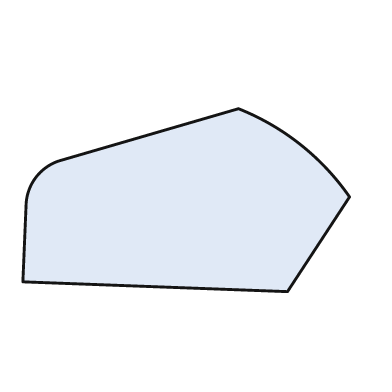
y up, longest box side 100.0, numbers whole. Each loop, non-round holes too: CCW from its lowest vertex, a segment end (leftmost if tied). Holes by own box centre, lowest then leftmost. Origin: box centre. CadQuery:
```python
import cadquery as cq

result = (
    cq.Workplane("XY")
    .moveTo(31.0, -28.0)
    .lineTo(50.0, 1.0)
    .threePointArc((35.0, 17.0), (16.0, 28.0))
    .lineTo(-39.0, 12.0)
    .threePointArc((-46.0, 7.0), (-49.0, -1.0))
    .lineTo(-50.0, -25.0)
    .close()
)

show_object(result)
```